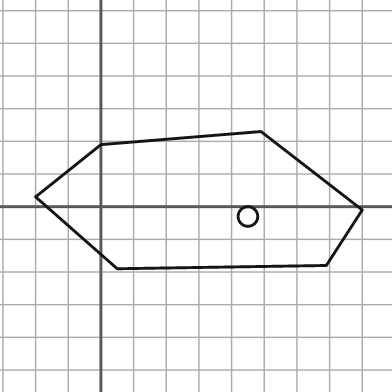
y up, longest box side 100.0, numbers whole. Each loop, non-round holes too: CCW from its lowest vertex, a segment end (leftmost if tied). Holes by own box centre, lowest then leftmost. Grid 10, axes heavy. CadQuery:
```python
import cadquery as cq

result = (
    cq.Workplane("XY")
    .moveTo(5.0, -19.0)
    .lineTo(69.0, -18.0)
    .lineTo(80.0, -1.0)
    .lineTo(49.0, 23.0)
    .lineTo(0.0, 19.0)
    .lineTo(-20.0, 3.0)
    .close()
    .moveTo(45.0, -3.0)
    .circle(3.0)
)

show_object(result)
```